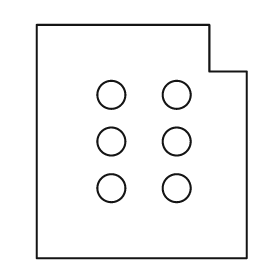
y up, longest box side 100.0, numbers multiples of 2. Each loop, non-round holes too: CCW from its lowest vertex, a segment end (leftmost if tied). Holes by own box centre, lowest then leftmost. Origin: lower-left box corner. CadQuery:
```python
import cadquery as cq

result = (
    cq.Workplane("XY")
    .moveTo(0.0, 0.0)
    .lineTo(90.0, 0.0)
    .lineTo(90.0, 80.0)
    .lineTo(74.0, 80.0)
    .lineTo(74.0, 100.0)
    .lineTo(0.0, 100.0)
    .close()
    .moveTo(32.0, 30.0)
    .circle(6.0)
    .moveTo(60.0, 30.0)
    .circle(6.0)
    .moveTo(32.0, 50.0)
    .circle(6.0)
    .moveTo(60.0, 50.0)
    .circle(6.0)
    .moveTo(32.0, 70.0)
    .circle(6.0)
    .moveTo(60.0, 70.0)
    .circle(6.0)
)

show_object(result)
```